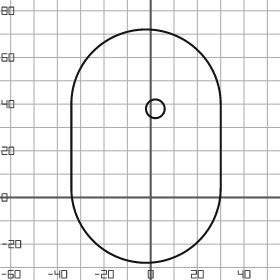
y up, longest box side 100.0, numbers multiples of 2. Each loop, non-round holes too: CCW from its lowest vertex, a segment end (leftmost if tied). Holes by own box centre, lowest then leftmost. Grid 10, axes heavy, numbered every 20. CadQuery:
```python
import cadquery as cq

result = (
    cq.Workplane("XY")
    .moveTo(-34.0, 4.0)
    .threePointArc((-2.0, -28.0), (30.0, 4.0))
    .lineTo(30.0, 40.0)
    .threePointArc((-2.0, 72.0), (-34.0, 40.0))
    .close()
    .moveTo(2.0, 38.0)
    .circle(4.0)
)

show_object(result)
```